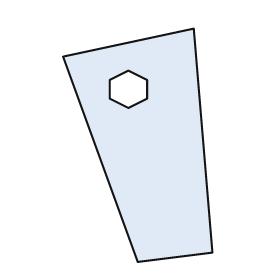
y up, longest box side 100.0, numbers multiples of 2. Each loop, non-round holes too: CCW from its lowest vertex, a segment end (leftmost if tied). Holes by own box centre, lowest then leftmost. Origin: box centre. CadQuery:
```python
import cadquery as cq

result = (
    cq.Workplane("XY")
    .moveTo(0.0, -50.0)
    .lineTo(32.0, -46.0)
    .lineTo(24.0, 50.0)
    .lineTo(-32.0, 38.0)
    .close()
    .moveTo(-4.0, 16.0)
    .lineTo(4.0, 20.0)
    .lineTo(4.0, 28.0)
    .lineTo(-4.0, 32.0)
    .lineTo(-12.0, 28.0)
    .lineTo(-12.0, 20.0)
    .close()
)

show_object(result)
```